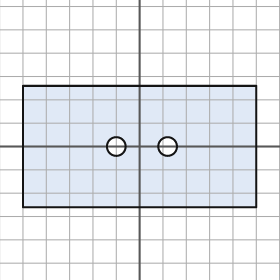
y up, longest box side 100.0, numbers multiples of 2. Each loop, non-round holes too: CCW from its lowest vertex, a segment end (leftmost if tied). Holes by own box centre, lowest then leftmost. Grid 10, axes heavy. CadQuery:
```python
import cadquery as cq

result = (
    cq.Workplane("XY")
    .moveTo(-50.0, -26.0)
    .lineTo(50.0, -26.0)
    .lineTo(50.0, 26.0)
    .lineTo(-50.0, 26.0)
    .close()
    .moveTo(-10.0, 0.0)
    .circle(4.0)
    .moveTo(12.0, 0.0)
    .circle(4.0)
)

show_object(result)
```